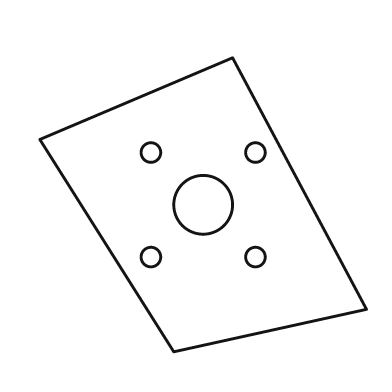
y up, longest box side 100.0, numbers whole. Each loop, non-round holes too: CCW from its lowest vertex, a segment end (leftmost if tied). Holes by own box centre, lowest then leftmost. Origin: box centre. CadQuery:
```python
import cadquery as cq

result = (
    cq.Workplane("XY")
    .moveTo(-9.0, -45.0)
    .lineTo(50.0, -32.0)
    .lineTo(9.0, 45.0)
    .lineTo(-50.0, 20.0)
    .close()
    .moveTo(-16.0, -16.0)
    .circle(3.0)
    .moveTo(16.0, -16.0)
    .circle(3.0)
    .moveTo(0.0, 0.0)
    .circle(9.0)
    .moveTo(-16.0, 16.0)
    .circle(3.0)
    .moveTo(16.0, 16.0)
    .circle(3.0)
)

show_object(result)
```